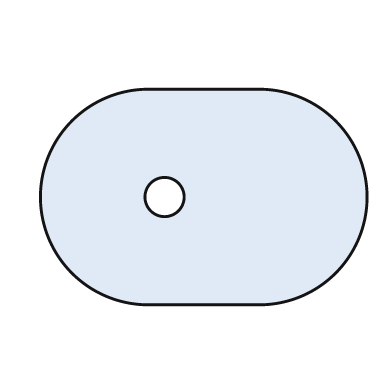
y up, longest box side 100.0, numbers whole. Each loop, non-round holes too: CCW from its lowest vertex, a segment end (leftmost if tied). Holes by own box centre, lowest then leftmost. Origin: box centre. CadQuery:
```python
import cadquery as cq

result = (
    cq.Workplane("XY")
    .moveTo(-17.0, -33.0)
    .lineTo(17.0, -33.0)
    .threePointArc((50.0, 0.0), (17.0, 33.0))
    .lineTo(-17.0, 33.0)
    .threePointArc((-50.0, 0.0), (-17.0, -33.0))
    .close()
    .moveTo(-12.0, 0.0)
    .circle(6.0)
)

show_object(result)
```